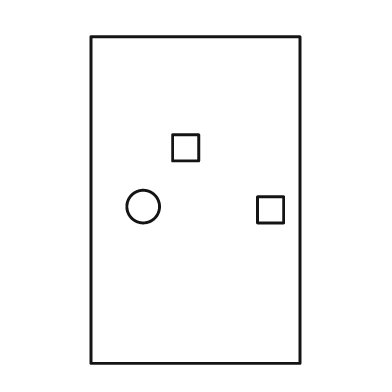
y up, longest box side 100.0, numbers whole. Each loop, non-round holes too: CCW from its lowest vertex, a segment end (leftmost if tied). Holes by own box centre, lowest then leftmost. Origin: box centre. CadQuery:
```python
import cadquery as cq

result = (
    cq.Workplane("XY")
    .moveTo(-32.0, -50.0)
    .lineTo(32.0, -50.0)
    .lineTo(32.0, 50.0)
    .lineTo(-32.0, 50.0)
    .close()
    .moveTo(19.0, -7.0)
    .lineTo(27.0, -7.0)
    .lineTo(27.0, 1.0)
    .lineTo(19.0, 1.0)
    .close()
    .moveTo(-16.0, -2.0)
    .circle(5.0)
    .moveTo(-7.0, 12.0)
    .lineTo(1.0, 12.0)
    .lineTo(1.0, 20.0)
    .lineTo(-7.0, 20.0)
    .close()
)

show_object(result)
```